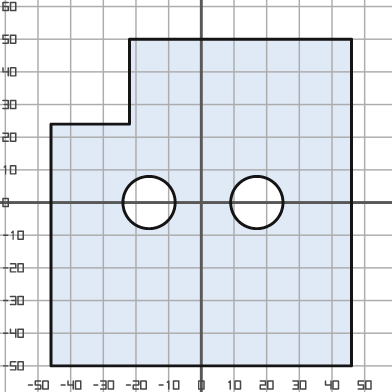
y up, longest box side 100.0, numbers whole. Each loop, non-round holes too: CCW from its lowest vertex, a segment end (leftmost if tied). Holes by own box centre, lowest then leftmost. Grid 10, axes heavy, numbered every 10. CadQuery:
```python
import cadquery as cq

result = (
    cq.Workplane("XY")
    .moveTo(-46.0, -50.0)
    .lineTo(46.0, -50.0)
    .lineTo(46.0, 50.0)
    .lineTo(-22.0, 50.0)
    .lineTo(-22.0, 24.0)
    .lineTo(-46.0, 24.0)
    .close()
    .moveTo(-16.0, 0.0)
    .circle(8.0)
    .moveTo(17.0, 0.0)
    .circle(8.0)
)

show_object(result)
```